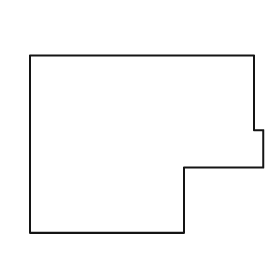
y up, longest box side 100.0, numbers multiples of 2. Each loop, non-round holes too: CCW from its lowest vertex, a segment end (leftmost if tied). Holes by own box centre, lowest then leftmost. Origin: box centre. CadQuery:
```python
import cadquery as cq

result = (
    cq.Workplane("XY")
    .moveTo(-50.0, -38.0)
    .lineTo(16.0, -38.0)
    .lineTo(16.0, -10.0)
    .lineTo(50.0, -10.0)
    .lineTo(50.0, 6.0)
    .lineTo(46.0, 6.0)
    .lineTo(46.0, 38.0)
    .lineTo(-50.0, 38.0)
    .close()
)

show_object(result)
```